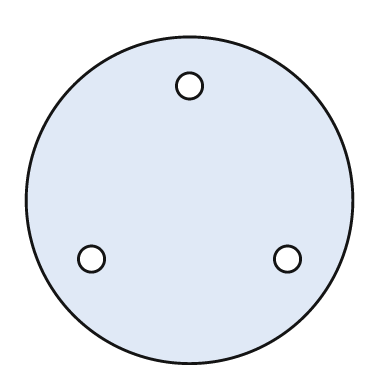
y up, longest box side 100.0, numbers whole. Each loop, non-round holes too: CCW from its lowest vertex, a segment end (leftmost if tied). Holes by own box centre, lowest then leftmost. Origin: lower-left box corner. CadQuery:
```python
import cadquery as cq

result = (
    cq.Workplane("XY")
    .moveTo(50.0, 50.0)
    .circle(50.0)
    .moveTo(20.0, 32.0)
    .circle(4.0)
    .moveTo(80.0, 32.0)
    .circle(4.0)
    .moveTo(50.0, 85.0)
    .circle(4.0)
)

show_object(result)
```